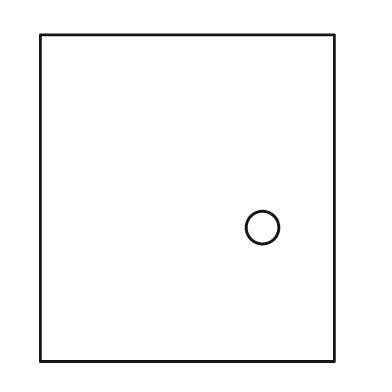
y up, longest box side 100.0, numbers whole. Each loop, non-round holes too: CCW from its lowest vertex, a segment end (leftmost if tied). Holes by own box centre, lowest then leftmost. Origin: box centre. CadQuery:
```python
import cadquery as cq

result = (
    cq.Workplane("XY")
    .moveTo(-45.0, -50.0)
    .lineTo(45.0, -50.0)
    .lineTo(45.0, 50.0)
    .lineTo(-45.0, 50.0)
    .close()
    .moveTo(23.0, -9.0)
    .circle(5.0)
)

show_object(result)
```